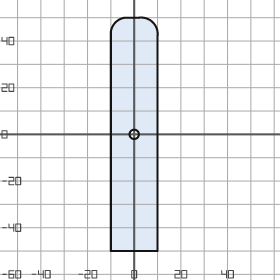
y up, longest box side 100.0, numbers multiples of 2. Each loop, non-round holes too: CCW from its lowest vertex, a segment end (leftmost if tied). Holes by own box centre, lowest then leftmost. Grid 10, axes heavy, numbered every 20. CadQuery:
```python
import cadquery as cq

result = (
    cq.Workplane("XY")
    .moveTo(-10.0, -50.0)
    .lineTo(10.0, -50.0)
    .lineTo(10.0, 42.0)
    .threePointArc((8.0, 48.0), (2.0, 50.0))
    .lineTo(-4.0, 50.0)
    .threePointArc((-8.0, 48.0), (-10.0, 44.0))
    .close()
    .moveTo(0.0, 0.0)
    .circle(2.0)
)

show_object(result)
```